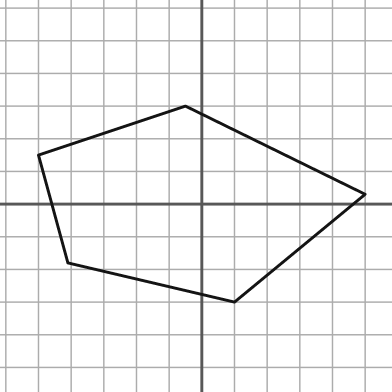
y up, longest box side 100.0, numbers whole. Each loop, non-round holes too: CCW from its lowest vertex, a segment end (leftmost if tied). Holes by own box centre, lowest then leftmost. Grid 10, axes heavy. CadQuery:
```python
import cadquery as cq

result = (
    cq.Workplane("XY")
    .moveTo(10.0, -30.0)
    .lineTo(50.0, 3.0)
    .lineTo(-5.0, 30.0)
    .lineTo(-50.0, 15.0)
    .lineTo(-41.0, -18.0)
    .close()
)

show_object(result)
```